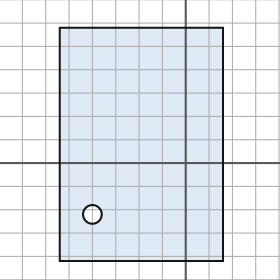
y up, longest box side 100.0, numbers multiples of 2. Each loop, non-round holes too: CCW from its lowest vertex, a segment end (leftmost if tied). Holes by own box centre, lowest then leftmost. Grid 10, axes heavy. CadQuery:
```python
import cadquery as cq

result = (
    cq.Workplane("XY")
    .moveTo(-54.0, -42.0)
    .lineTo(16.0, -42.0)
    .lineTo(16.0, 58.0)
    .lineTo(-54.0, 58.0)
    .close()
    .moveTo(-40.0, -22.0)
    .circle(4.0)
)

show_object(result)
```